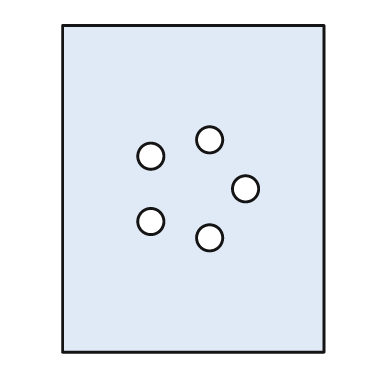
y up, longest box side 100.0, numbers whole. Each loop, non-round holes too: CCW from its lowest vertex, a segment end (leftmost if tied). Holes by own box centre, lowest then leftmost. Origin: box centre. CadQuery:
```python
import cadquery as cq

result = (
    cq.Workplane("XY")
    .moveTo(-40.0, -50.0)
    .lineTo(40.0, -50.0)
    .lineTo(40.0, 50.0)
    .lineTo(-40.0, 50.0)
    .close()
    .moveTo(5.0, -15.0)
    .circle(4.0)
    .moveTo(-13.0, -10.0)
    .circle(4.0)
    .moveTo(16.0, 0.0)
    .circle(4.0)
    .moveTo(-13.0, 10.0)
    .circle(4.0)
    .moveTo(5.0, 15.0)
    .circle(4.0)
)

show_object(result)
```